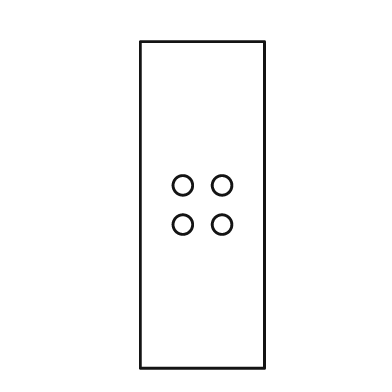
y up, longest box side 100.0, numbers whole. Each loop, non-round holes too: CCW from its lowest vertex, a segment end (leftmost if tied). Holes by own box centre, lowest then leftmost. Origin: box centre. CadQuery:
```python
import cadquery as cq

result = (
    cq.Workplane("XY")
    .moveTo(-19.0, -50.0)
    .lineTo(19.0, -50.0)
    .lineTo(19.0, 50.0)
    .lineTo(-19.0, 50.0)
    .close()
    .moveTo(-6.0, -6.0)
    .circle(3.0)
    .moveTo(6.0, -6.0)
    .circle(3.0)
    .moveTo(-6.0, 6.0)
    .circle(3.0)
    .moveTo(6.0, 6.0)
    .circle(3.0)
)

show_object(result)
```